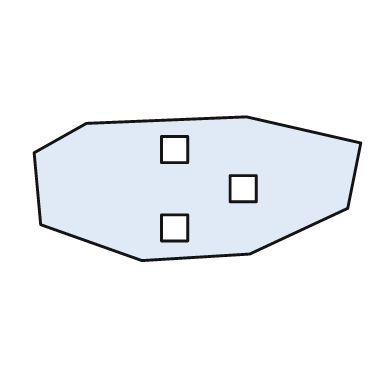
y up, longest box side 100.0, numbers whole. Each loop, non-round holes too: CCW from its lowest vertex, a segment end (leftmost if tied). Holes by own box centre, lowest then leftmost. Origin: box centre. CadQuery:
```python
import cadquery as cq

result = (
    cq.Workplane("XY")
    .moveTo(-17.0, -22.0)
    .lineTo(16.0, -20.0)
    .lineTo(46.0, -6.0)
    .lineTo(50.0, 14.0)
    .lineTo(15.0, 22.0)
    .lineTo(-34.0, 20.0)
    .lineTo(-50.0, 11.0)
    .lineTo(-48.0, -11.0)
    .close()
    .moveTo(-11.0, -16.0)
    .lineTo(-3.0, -16.0)
    .lineTo(-3.0, -8.0)
    .lineTo(-11.0, -8.0)
    .close()
    .moveTo(10.0, -4.0)
    .lineTo(18.0, -4.0)
    .lineTo(18.0, 4.0)
    .lineTo(10.0, 4.0)
    .close()
    .moveTo(-11.0, 8.0)
    .lineTo(-3.0, 8.0)
    .lineTo(-3.0, 16.0)
    .lineTo(-11.0, 16.0)
    .close()
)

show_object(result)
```